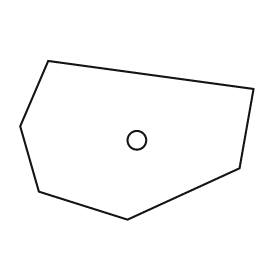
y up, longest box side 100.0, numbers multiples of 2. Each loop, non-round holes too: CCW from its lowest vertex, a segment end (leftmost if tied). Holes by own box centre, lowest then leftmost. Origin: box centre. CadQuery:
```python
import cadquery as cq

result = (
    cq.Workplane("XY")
    .moveTo(-4.0, -34.0)
    .lineTo(44.0, -12.0)
    .lineTo(50.0, 22.0)
    .lineTo(-38.0, 34.0)
    .lineTo(-50.0, 6.0)
    .lineTo(-42.0, -22.0)
    .close()
    .moveTo(0.0, 0.0)
    .circle(4.0)
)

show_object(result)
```